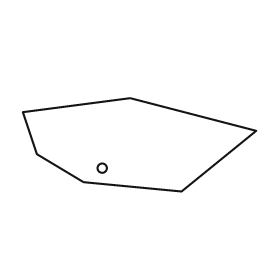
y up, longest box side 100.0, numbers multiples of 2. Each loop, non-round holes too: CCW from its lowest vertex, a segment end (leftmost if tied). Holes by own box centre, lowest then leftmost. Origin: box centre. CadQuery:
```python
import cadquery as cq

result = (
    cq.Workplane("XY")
    .moveTo(18.0, -20.0)
    .lineTo(50.0, 6.0)
    .lineTo(-4.0, 20.0)
    .lineTo(-50.0, 14.0)
    .lineTo(-44.0, -4.0)
    .lineTo(-24.0, -16.0)
    .close()
    .moveTo(-16.0, -10.0)
    .circle(2.0)
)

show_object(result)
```